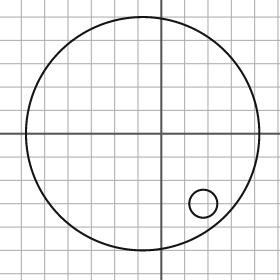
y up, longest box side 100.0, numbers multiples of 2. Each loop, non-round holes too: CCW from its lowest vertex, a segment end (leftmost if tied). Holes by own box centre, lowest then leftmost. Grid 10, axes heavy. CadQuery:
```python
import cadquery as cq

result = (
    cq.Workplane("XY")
    .moveTo(-8.0, 0.0)
    .circle(50.0)
    .moveTo(18.0, -30.0)
    .circle(6.0)
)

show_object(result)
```